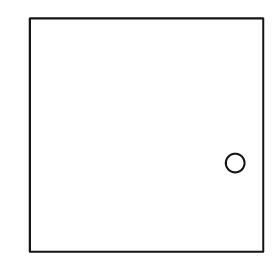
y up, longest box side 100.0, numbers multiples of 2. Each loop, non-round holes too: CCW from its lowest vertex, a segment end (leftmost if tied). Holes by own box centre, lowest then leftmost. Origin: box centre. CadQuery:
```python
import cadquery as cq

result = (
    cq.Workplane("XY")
    .moveTo(-50.0, -50.0)
    .lineTo(50.0, -50.0)
    .lineTo(50.0, 50.0)
    .lineTo(-50.0, 50.0)
    .close()
    .moveTo(38.0, -12.0)
    .circle(4.0)
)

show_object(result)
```